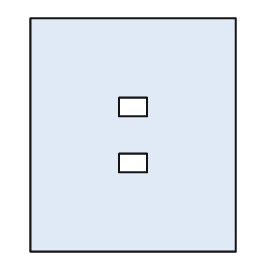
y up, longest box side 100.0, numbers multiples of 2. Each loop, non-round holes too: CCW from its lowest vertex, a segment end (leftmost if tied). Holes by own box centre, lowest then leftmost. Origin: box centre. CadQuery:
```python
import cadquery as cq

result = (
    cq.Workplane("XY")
    .moveTo(-44.0, -50.0)
    .lineTo(44.0, -50.0)
    .lineTo(44.0, 50.0)
    .lineTo(-44.0, 50.0)
    .close()
    .moveTo(-6.0, -16.0)
    .lineTo(6.0, -16.0)
    .lineTo(6.0, -8.0)
    .lineTo(-6.0, -8.0)
    .close()
    .moveTo(-6.0, 8.0)
    .lineTo(6.0, 8.0)
    .lineTo(6.0, 16.0)
    .lineTo(-6.0, 16.0)
    .close()
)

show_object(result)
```